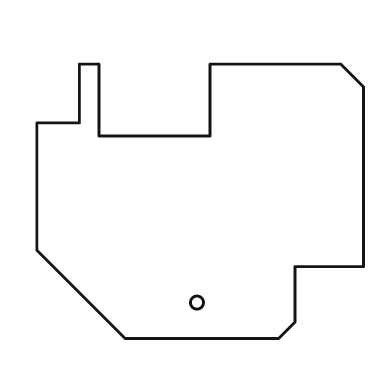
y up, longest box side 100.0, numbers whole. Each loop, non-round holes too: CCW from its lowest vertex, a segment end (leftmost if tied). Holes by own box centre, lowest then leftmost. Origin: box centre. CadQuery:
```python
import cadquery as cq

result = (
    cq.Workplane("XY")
    .moveTo(-23.0, -42.0)
    .lineTo(24.0, -42.0)
    .lineTo(29.0, -37.0)
    .lineTo(29.0, -20.0)
    .lineTo(50.0, -20.0)
    .lineTo(50.0, 35.0)
    .lineTo(43.0, 42.0)
    .lineTo(3.0, 42.0)
    .lineTo(3.0, 20.0)
    .lineTo(-31.0, 20.0)
    .lineTo(-31.0, 42.0)
    .lineTo(-37.0, 42.0)
    .lineTo(-37.0, 24.0)
    .lineTo(-50.0, 24.0)
    .lineTo(-50.0, -15.0)
    .close()
    .moveTo(-1.0, -31.0)
    .circle(2.0)
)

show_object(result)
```